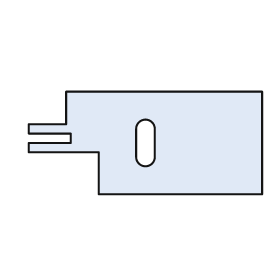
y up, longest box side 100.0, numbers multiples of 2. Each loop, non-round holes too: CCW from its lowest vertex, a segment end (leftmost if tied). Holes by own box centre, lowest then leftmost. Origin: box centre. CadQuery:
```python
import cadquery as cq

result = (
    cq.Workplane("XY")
    .moveTo(-20.0, -22.0)
    .lineTo(50.0, -22.0)
    .lineTo(50.0, 22.0)
    .lineTo(-34.0, 22.0)
    .lineTo(-34.0, 8.0)
    .lineTo(-50.0, 8.0)
    .lineTo(-50.0, 4.0)
    .lineTo(-32.0, 4.0)
    .lineTo(-32.0, 0.0)
    .lineTo(-50.0, 0.0)
    .lineTo(-50.0, -4.0)
    .lineTo(-20.0, -4.0)
    .close()
    .moveTo(-4.0, -6.0)
    .threePointArc((0.0, -10.0), (4.0, -6.0))
    .lineTo(4.0, 6.0)
    .threePointArc((0.0, 10.0), (-4.0, 6.0))
    .close()
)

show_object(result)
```